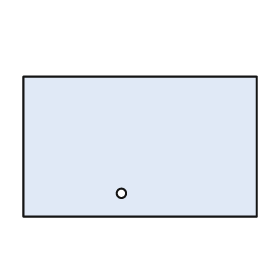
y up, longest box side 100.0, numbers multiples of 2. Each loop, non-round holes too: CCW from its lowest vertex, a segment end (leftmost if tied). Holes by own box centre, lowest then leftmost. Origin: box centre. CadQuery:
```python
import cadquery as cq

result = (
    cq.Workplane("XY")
    .moveTo(-50.0, -30.0)
    .lineTo(50.0, -30.0)
    .lineTo(50.0, 30.0)
    .lineTo(-50.0, 30.0)
    .close()
    .moveTo(-8.0, -20.0)
    .circle(2.0)
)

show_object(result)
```